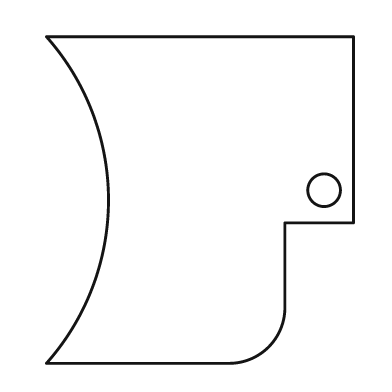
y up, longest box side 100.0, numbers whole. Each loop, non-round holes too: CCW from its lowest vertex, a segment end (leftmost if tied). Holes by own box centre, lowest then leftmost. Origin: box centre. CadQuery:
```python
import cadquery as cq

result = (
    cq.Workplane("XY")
    .moveTo(-47.0, -50.0)
    .lineTo(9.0, -50.0)
    .threePointArc((21.0, -45.0), (26.0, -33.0))
    .lineTo(26.0, -7.0)
    .lineTo(47.0, -7.0)
    .lineTo(47.0, 50.0)
    .lineTo(-47.0, 50.0)
    .threePointArc((-28.0, 0.0), (-47.0, -50.0))
    .close()
    .moveTo(38.0, 3.0)
    .circle(5.0)
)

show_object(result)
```